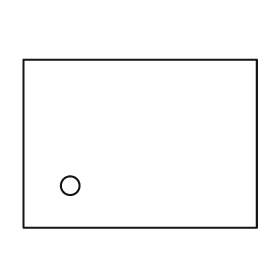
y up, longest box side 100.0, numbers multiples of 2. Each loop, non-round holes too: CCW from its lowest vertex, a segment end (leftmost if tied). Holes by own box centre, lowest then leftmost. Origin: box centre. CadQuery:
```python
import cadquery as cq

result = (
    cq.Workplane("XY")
    .moveTo(-50.0, -36.0)
    .lineTo(50.0, -36.0)
    .lineTo(50.0, 36.0)
    .lineTo(-50.0, 36.0)
    .close()
    .moveTo(-30.0, -18.0)
    .circle(4.0)
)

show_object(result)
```